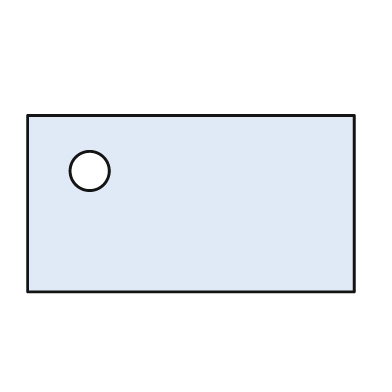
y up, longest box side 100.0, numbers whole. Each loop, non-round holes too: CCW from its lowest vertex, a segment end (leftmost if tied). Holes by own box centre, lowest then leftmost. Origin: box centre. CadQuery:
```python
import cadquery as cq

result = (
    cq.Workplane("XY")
    .moveTo(-50.0, -27.0)
    .lineTo(50.0, -27.0)
    .lineTo(50.0, 27.0)
    .lineTo(-50.0, 27.0)
    .close()
    .moveTo(-31.0, 10.0)
    .circle(6.0)
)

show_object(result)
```